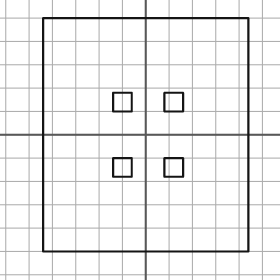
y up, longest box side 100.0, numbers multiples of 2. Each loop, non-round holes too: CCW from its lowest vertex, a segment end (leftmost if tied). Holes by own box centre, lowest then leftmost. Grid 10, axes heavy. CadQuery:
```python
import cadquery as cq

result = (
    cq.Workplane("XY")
    .moveTo(-44.0, -50.0)
    .lineTo(44.0, -50.0)
    .lineTo(44.0, 50.0)
    .lineTo(-44.0, 50.0)
    .close()
    .moveTo(-14.0, -18.0)
    .lineTo(-6.0, -18.0)
    .lineTo(-6.0, -10.0)
    .lineTo(-14.0, -10.0)
    .close()
    .moveTo(8.0, -18.0)
    .lineTo(16.0, -18.0)
    .lineTo(16.0, -10.0)
    .lineTo(8.0, -10.0)
    .close()
    .moveTo(-14.0, 10.0)
    .lineTo(-6.0, 10.0)
    .lineTo(-6.0, 18.0)
    .lineTo(-14.0, 18.0)
    .close()
    .moveTo(8.0, 10.0)
    .lineTo(16.0, 10.0)
    .lineTo(16.0, 18.0)
    .lineTo(8.0, 18.0)
    .close()
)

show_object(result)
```